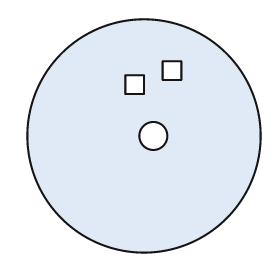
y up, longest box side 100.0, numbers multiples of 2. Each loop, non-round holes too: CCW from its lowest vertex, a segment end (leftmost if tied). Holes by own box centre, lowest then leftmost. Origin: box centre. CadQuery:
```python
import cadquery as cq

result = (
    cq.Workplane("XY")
    .moveTo(0.0, 0.0)
    .circle(50.0)
    .moveTo(4.0, 0.0)
    .circle(6.0)
    .moveTo(-8.0, 18.0)
    .lineTo(0.0, 18.0)
    .lineTo(0.0, 26.0)
    .lineTo(-8.0, 26.0)
    .close()
    .moveTo(8.0, 24.0)
    .lineTo(16.0, 24.0)
    .lineTo(16.0, 32.0)
    .lineTo(8.0, 32.0)
    .close()
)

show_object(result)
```